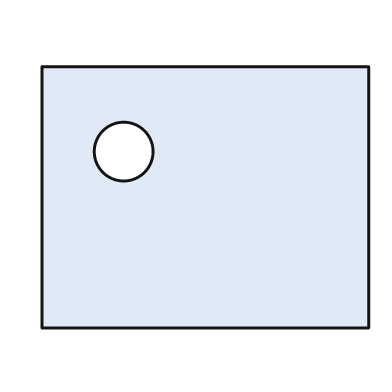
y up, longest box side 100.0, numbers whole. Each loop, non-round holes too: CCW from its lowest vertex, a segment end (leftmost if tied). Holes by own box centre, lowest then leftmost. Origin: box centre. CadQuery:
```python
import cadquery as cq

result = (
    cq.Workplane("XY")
    .moveTo(-50.0, -40.0)
    .lineTo(50.0, -40.0)
    .lineTo(50.0, 40.0)
    .lineTo(-50.0, 40.0)
    .close()
    .moveTo(-25.0, 14.0)
    .circle(9.0)
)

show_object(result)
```